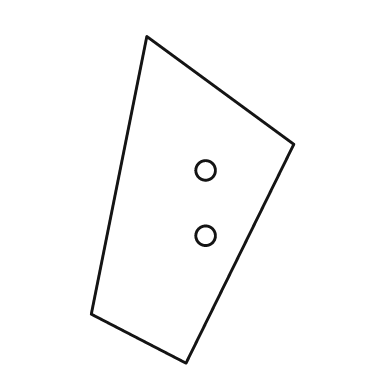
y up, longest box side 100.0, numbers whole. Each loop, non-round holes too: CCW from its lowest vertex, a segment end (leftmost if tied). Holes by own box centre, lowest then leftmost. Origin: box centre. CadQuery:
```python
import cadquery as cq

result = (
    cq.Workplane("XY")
    .moveTo(-2.0, -50.0)
    .lineTo(31.0, 17.0)
    .lineTo(-14.0, 50.0)
    .lineTo(-31.0, -35.0)
    .close()
    .moveTo(4.0, -11.0)
    .circle(3.0)
    .moveTo(4.0, 9.0)
    .circle(3.0)
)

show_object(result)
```